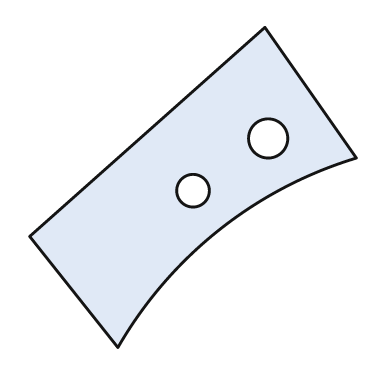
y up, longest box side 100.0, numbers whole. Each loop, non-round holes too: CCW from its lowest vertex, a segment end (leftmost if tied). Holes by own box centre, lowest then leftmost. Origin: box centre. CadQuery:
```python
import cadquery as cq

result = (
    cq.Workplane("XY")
    .moveTo(-23.0, -49.0)
    .threePointArc((8.0, -13.0), (50.0, 9.0))
    .lineTo(22.0, 49.0)
    .lineTo(-50.0, -15.0)
    .close()
    .moveTo(0.0, -1.0)
    .circle(5.0)
    .moveTo(23.0, 15.0)
    .circle(6.0)
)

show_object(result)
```